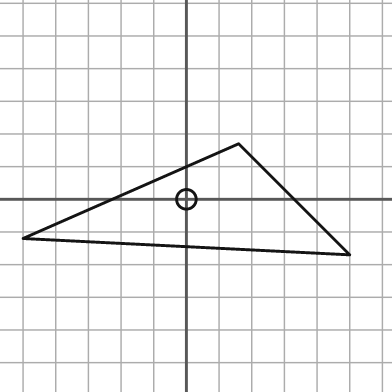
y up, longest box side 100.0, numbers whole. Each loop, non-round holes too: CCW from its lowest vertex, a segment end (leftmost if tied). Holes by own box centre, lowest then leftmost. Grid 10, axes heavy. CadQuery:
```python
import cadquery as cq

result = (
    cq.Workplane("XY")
    .moveTo(50.0, -17.0)
    .lineTo(16.0, 17.0)
    .lineTo(-50.0, -12.0)
    .close()
    .moveTo(0.0, 0.0)
    .circle(3.0)
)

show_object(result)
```